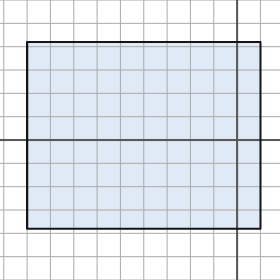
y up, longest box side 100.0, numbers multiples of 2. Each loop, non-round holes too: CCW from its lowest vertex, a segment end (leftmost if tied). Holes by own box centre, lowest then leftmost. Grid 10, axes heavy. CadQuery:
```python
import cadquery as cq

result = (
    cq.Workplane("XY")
    .moveTo(-90.0, -38.0)
    .lineTo(10.0, -38.0)
    .lineTo(10.0, 42.0)
    .lineTo(-90.0, 42.0)
    .close()
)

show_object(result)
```